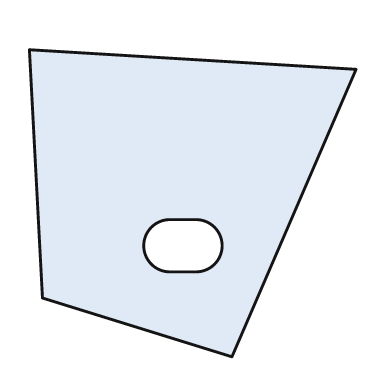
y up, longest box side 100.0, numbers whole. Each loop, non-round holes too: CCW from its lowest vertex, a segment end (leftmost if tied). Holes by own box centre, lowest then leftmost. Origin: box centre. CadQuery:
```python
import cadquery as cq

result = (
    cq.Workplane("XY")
    .moveTo(12.0, -47.0)
    .lineTo(50.0, 41.0)
    .lineTo(-50.0, 47.0)
    .lineTo(-46.0, -29.0)
    .close()
    .moveTo(-7.0, -21.0)
    .lineTo(1.0, -21.0)
    .threePointArc((9.0, -13.0), (1.0, -5.0))
    .lineTo(-7.0, -5.0)
    .threePointArc((-15.0, -13.0), (-7.0, -21.0))
    .close()
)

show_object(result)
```